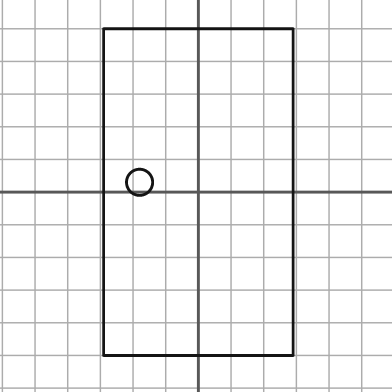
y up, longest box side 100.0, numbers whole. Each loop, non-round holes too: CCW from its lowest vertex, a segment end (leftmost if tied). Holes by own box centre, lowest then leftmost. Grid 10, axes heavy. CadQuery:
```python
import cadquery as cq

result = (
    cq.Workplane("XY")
    .moveTo(-29.0, -50.0)
    .lineTo(29.0, -50.0)
    .lineTo(29.0, 50.0)
    .lineTo(-29.0, 50.0)
    .close()
    .moveTo(-18.0, 3.0)
    .circle(4.0)
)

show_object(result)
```